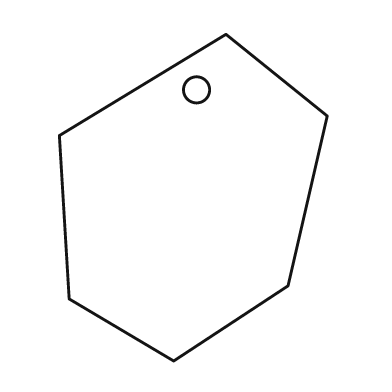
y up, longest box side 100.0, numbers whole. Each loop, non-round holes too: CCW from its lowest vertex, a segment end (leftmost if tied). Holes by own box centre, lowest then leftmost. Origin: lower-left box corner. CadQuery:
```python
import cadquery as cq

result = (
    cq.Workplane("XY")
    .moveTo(35.0, 0.0)
    .lineTo(70.0, 23.0)
    .lineTo(82.0, 75.0)
    .lineTo(51.0, 100.0)
    .lineTo(0.0, 69.0)
    .lineTo(3.0, 19.0)
    .close()
    .moveTo(42.0, 83.0)
    .circle(4.0)
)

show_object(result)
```